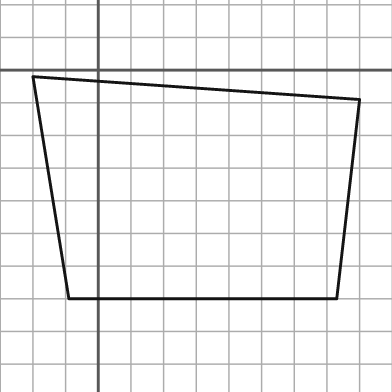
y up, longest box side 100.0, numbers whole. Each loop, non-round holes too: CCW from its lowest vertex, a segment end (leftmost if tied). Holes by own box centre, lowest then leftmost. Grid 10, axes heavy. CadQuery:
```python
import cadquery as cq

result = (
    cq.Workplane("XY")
    .moveTo(-9.0, -70.0)
    .lineTo(73.0, -70.0)
    .lineTo(80.0, -9.0)
    .lineTo(-20.0, -2.0)
    .close()
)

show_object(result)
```